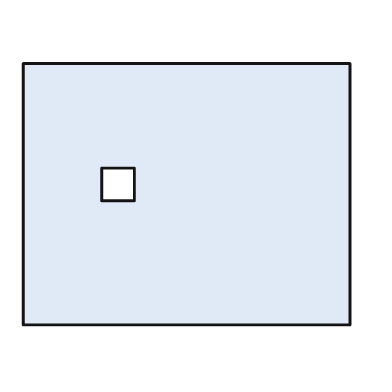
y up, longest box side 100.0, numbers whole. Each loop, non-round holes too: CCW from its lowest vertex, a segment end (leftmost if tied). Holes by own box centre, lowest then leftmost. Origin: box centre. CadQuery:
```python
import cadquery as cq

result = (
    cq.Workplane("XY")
    .moveTo(-50.0, -40.0)
    .lineTo(50.0, -40.0)
    .lineTo(50.0, 40.0)
    .lineTo(-50.0, 40.0)
    .close()
    .moveTo(-26.0, -2.0)
    .lineTo(-16.0, -2.0)
    .lineTo(-16.0, 8.0)
    .lineTo(-26.0, 8.0)
    .close()
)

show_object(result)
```